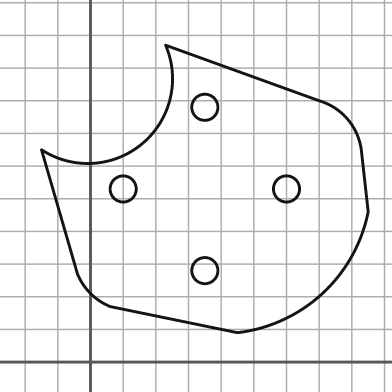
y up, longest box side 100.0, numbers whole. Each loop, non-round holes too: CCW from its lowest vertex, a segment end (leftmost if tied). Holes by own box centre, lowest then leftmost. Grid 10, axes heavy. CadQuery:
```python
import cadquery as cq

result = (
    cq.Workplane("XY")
    .moveTo(45.0, 9.0)
    .threePointArc((71.0, 21.0), (85.0, 46.0))
    .lineTo(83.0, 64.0)
    .threePointArc((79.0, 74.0), (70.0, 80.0))
    .lineTo(23.0, 97.0)
    .threePointArc((16.0, 67.0), (-15.0, 65.0))
    .lineTo(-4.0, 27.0)
    .threePointArc((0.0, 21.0), (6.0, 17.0))
    .close()
    .moveTo(35.0, 28.0)
    .circle(4.0)
    .moveTo(10.0, 53.0)
    .circle(4.0)
    .moveTo(60.0, 53.0)
    .circle(4.0)
    .moveTo(35.0, 78.0)
    .circle(4.0)
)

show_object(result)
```